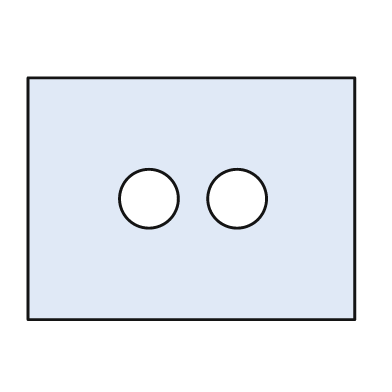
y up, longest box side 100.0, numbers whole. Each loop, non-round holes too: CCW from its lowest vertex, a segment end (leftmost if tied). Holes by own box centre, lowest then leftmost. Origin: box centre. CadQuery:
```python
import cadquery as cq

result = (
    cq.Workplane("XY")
    .moveTo(-50.0, -37.0)
    .lineTo(50.0, -37.0)
    .lineTo(50.0, 37.0)
    .lineTo(-50.0, 37.0)
    .close()
    .moveTo(-13.0, 0.0)
    .circle(9.0)
    .moveTo(14.0, 0.0)
    .circle(9.0)
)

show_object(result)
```